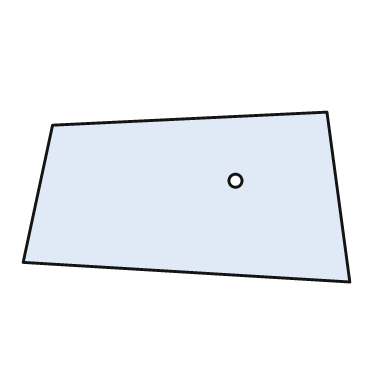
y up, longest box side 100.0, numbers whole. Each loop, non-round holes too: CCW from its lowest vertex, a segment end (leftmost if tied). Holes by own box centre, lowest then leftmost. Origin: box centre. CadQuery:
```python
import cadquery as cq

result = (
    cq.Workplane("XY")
    .moveTo(50.0, -26.0)
    .lineTo(43.0, 26.0)
    .lineTo(-41.0, 22.0)
    .lineTo(-50.0, -20.0)
    .close()
    .moveTo(15.0, 5.0)
    .circle(2.0)
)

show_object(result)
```